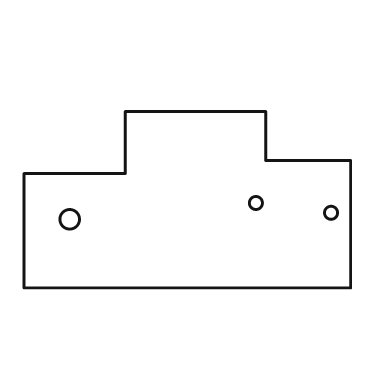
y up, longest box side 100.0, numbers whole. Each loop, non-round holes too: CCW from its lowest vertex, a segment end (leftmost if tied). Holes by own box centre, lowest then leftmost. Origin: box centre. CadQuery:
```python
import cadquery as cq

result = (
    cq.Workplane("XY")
    .moveTo(-50.0, -27.0)
    .lineTo(50.0, -27.0)
    .lineTo(50.0, 12.0)
    .lineTo(24.0, 12.0)
    .lineTo(24.0, 27.0)
    .lineTo(-19.0, 27.0)
    .lineTo(-19.0, 8.0)
    .lineTo(-50.0, 8.0)
    .close()
    .moveTo(-36.0, -6.0)
    .circle(3.0)
    .moveTo(44.0, -4.0)
    .circle(2.0)
    .moveTo(21.0, -1.0)
    .circle(2.0)
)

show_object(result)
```